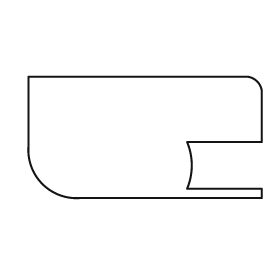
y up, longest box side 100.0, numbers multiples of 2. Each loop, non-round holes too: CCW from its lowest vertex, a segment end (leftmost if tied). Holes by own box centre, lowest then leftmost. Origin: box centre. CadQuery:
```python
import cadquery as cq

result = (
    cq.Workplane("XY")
    .moveTo(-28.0, -26.0)
    .lineTo(50.0, -26.0)
    .lineTo(50.0, -22.0)
    .lineTo(18.0, -22.0)
    .threePointArc((20.0, -12.0), (18.0, -2.0))
    .lineTo(50.0, -2.0)
    .lineTo(50.0, 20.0)
    .threePointArc((48.0, 24.0), (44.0, 26.0))
    .lineTo(-50.0, 26.0)
    .lineTo(-50.0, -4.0)
    .threePointArc((-44.0, -20.0), (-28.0, -26.0))
    .close()
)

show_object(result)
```